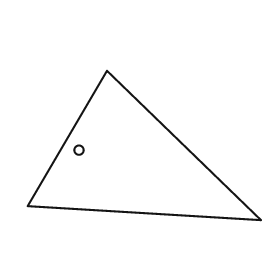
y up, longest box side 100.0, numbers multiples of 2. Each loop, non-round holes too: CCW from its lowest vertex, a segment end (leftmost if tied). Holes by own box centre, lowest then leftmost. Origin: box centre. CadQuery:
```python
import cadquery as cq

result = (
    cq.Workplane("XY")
    .moveTo(50.0, -32.0)
    .lineTo(-16.0, 32.0)
    .lineTo(-50.0, -26.0)
    .close()
    .moveTo(-28.0, -2.0)
    .circle(2.0)
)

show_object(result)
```